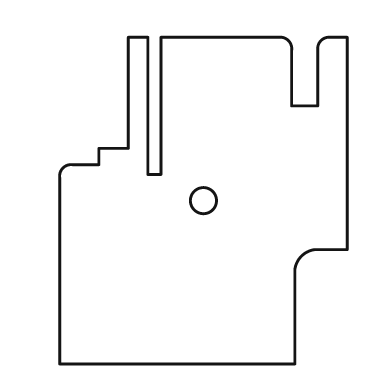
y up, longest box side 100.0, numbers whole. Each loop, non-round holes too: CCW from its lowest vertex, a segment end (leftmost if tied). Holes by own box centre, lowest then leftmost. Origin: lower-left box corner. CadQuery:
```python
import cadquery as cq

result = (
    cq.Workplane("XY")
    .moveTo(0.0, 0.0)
    .lineTo(72.0, 0.0)
    .lineTo(72.0, 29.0)
    .threePointArc((74.0, 33.0), (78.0, 35.0))
    .lineTo(88.0, 35.0)
    .lineTo(88.0, 100.0)
    .lineTo(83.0, 100.0)
    .threePointArc((80.0, 99.0), (79.0, 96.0))
    .lineTo(79.0, 79.0)
    .lineTo(71.0, 79.0)
    .lineTo(71.0, 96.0)
    .threePointArc((70.0, 99.0), (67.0, 100.0))
    .lineTo(31.0, 100.0)
    .lineTo(31.0, 58.0)
    .lineTo(27.0, 58.0)
    .lineTo(27.0, 100.0)
    .lineTo(21.0, 100.0)
    .lineTo(21.0, 66.0)
    .lineTo(12.0, 66.0)
    .lineTo(12.0, 61.0)
    .lineTo(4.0, 61.0)
    .threePointArc((1.0, 60.0), (0.0, 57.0))
    .close()
    .moveTo(44.0, 50.0)
    .circle(4.0)
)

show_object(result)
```